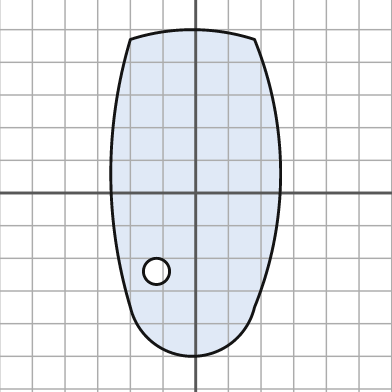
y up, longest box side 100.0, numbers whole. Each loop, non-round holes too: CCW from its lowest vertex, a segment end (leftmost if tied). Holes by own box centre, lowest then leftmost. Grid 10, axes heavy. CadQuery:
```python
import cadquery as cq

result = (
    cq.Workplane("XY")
    .moveTo(-20.0, -35.0)
    .threePointArc((-1.0, -50.0), (18.0, -35.0))
    .threePointArc((26.0, 6.0), (18.0, 47.0))
    .threePointArc((-1.0, 50.0), (-20.0, 47.0))
    .threePointArc((-26.0, 6.0), (-20.0, -35.0))
    .close()
    .moveTo(-12.0, -24.0)
    .circle(4.0)
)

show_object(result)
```